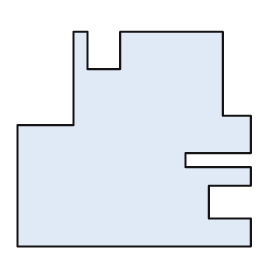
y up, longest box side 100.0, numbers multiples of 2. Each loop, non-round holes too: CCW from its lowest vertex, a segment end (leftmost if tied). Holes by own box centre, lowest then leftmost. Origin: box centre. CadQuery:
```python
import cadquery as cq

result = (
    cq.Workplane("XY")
    .moveTo(-50.0, -46.0)
    .lineTo(50.0, -46.0)
    .lineTo(50.0, -34.0)
    .lineTo(32.0, -34.0)
    .lineTo(32.0, -20.0)
    .lineTo(50.0, -20.0)
    .lineTo(50.0, -12.0)
    .lineTo(22.0, -12.0)
    .lineTo(22.0, -6.0)
    .lineTo(50.0, -6.0)
    .lineTo(50.0, 10.0)
    .lineTo(38.0, 10.0)
    .lineTo(38.0, 46.0)
    .lineTo(-6.0, 46.0)
    .lineTo(-6.0, 30.0)
    .lineTo(-20.0, 30.0)
    .lineTo(-20.0, 46.0)
    .lineTo(-26.0, 46.0)
    .lineTo(-26.0, 6.0)
    .lineTo(-50.0, 6.0)
    .close()
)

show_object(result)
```